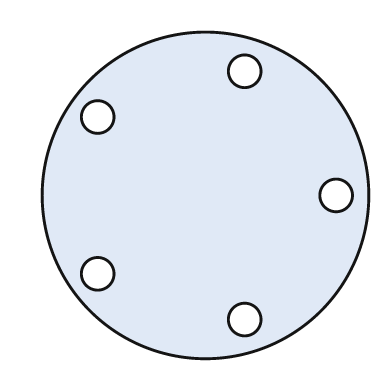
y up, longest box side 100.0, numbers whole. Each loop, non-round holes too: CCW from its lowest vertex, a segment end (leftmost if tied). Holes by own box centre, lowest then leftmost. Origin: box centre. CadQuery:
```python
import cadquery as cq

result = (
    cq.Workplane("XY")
    .moveTo(0.0, 0.0)
    .circle(50.0)
    .moveTo(12.0, -38.0)
    .circle(5.0)
    .moveTo(-33.0, -24.0)
    .circle(5.0)
    .moveTo(40.0, 0.0)
    .circle(5.0)
    .moveTo(-33.0, 24.0)
    .circle(5.0)
    .moveTo(12.0, 38.0)
    .circle(5.0)
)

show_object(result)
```